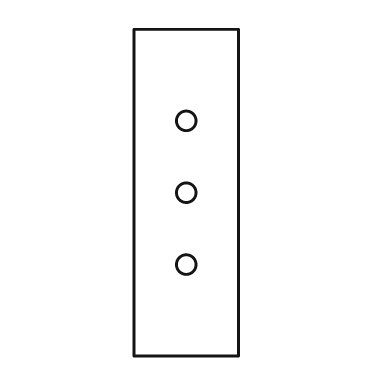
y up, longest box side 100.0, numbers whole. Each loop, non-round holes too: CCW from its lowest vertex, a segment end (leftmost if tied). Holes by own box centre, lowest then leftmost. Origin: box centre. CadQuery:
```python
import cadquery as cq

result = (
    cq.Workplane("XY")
    .moveTo(-16.0, -50.0)
    .lineTo(16.0, -50.0)
    .lineTo(16.0, 50.0)
    .lineTo(-16.0, 50.0)
    .close()
    .moveTo(0.0, -22.0)
    .circle(3.0)
    .moveTo(0.0, 0.0)
    .circle(3.0)
    .moveTo(0.0, 22.0)
    .circle(3.0)
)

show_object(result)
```